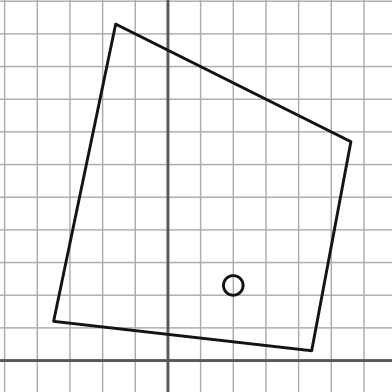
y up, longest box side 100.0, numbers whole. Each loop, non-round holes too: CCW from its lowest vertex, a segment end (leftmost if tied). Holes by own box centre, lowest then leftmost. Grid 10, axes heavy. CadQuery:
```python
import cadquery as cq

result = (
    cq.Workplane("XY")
    .moveTo(44.0, 3.0)
    .lineTo(56.0, 67.0)
    .lineTo(-16.0, 103.0)
    .lineTo(-35.0, 12.0)
    .close()
    .moveTo(20.0, 23.0)
    .circle(3.0)
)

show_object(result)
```